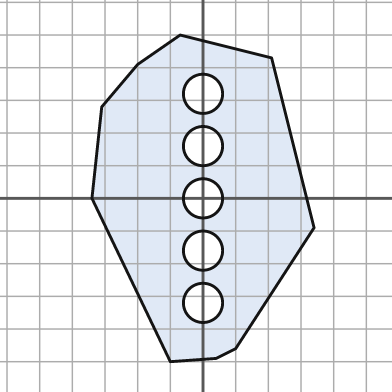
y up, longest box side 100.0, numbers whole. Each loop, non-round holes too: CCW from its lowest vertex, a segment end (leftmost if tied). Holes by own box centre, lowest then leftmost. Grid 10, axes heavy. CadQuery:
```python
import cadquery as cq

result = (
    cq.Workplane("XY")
    .moveTo(-10.0, -50.0)
    .lineTo(4.0, -49.0)
    .lineTo(10.0, -46.0)
    .lineTo(34.0, -9.0)
    .lineTo(21.0, 43.0)
    .lineTo(-7.0, 50.0)
    .lineTo(-20.0, 41.0)
    .lineTo(-31.0, 28.0)
    .lineTo(-34.0, 0.0)
    .close()
    .moveTo(0.0, -32.0)
    .circle(6.0)
    .moveTo(0.0, -16.0)
    .circle(6.0)
    .moveTo(0.0, 0.0)
    .circle(6.0)
    .moveTo(0.0, 16.0)
    .circle(6.0)
    .moveTo(0.0, 32.0)
    .circle(6.0)
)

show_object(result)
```